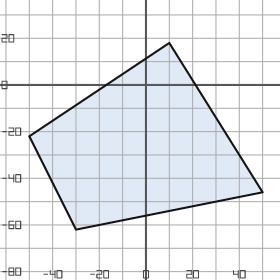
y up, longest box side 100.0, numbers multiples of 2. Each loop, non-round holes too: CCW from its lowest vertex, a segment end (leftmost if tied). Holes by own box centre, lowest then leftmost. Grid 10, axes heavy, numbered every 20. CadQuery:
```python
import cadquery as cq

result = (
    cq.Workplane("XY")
    .moveTo(-30.0, -62.0)
    .lineTo(50.0, -46.0)
    .lineTo(10.0, 18.0)
    .lineTo(-50.0, -22.0)
    .close()
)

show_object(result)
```